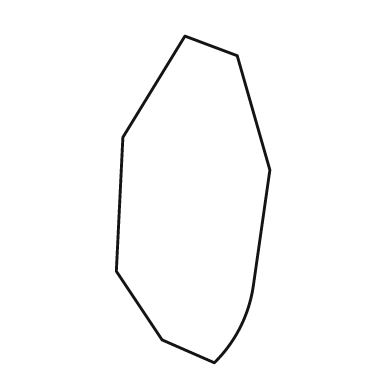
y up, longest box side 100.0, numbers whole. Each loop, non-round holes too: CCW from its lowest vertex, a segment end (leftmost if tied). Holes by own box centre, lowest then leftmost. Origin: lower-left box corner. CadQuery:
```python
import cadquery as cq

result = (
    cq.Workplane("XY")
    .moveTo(30.0, 0.0)
    .threePointArc((38.0, 11.0), (42.0, 24.0))
    .lineTo(47.0, 59.0)
    .lineTo(37.0, 94.0)
    .lineTo(21.0, 100.0)
    .lineTo(2.0, 69.0)
    .lineTo(0.0, 28.0)
    .lineTo(14.0, 7.0)
    .close()
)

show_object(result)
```